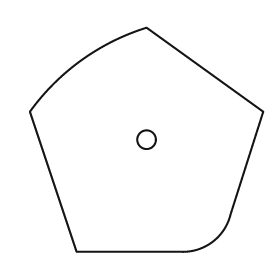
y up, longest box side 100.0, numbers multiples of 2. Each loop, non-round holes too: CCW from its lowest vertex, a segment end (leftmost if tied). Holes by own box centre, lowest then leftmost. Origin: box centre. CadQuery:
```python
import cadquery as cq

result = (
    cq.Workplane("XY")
    .moveTo(-30.0, -48.0)
    .lineTo(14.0, -48.0)
    .threePointArc((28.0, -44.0), (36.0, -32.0))
    .lineTo(50.0, 12.0)
    .lineTo(0.0, 48.0)
    .threePointArc((-28.0, 34.0), (-50.0, 12.0))
    .close()
    .moveTo(0.0, 0.0)
    .circle(4.0)
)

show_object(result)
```